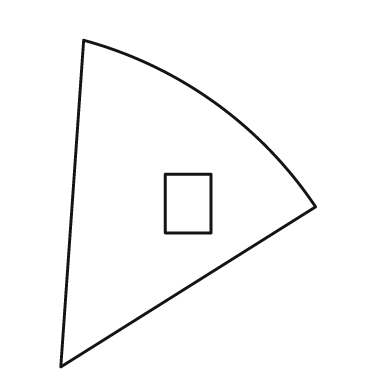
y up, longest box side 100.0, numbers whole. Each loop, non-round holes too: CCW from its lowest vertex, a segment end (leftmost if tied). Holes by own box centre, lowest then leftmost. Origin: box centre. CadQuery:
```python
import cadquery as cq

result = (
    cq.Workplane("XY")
    .moveTo(-39.0, -50.0)
    .lineTo(39.0, -1.0)
    .threePointArc((8.0, 31.0), (-32.0, 50.0))
    .close()
    .moveTo(-7.0, -9.0)
    .lineTo(7.0, -9.0)
    .lineTo(7.0, 9.0)
    .lineTo(-7.0, 9.0)
    .close()
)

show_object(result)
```